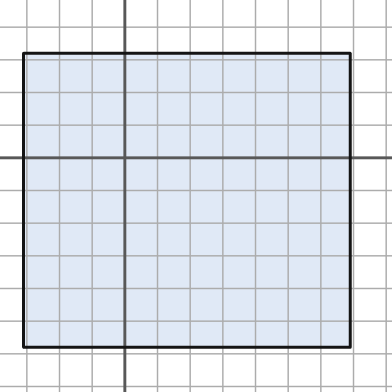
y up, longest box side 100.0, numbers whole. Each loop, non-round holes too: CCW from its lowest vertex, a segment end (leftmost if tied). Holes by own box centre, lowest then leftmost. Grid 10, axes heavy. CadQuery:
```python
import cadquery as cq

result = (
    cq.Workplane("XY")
    .moveTo(-31.0, -58.0)
    .lineTo(69.0, -58.0)
    .lineTo(69.0, 32.0)
    .lineTo(-31.0, 32.0)
    .close()
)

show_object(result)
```